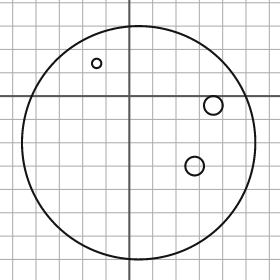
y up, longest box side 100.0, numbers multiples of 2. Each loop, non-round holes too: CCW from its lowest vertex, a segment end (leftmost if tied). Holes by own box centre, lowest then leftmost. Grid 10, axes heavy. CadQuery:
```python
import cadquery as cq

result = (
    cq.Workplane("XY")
    .moveTo(4.0, -20.0)
    .circle(50.0)
    .moveTo(28.0, -30.0)
    .circle(4.0)
    .moveTo(36.0, -4.0)
    .circle(4.0)
    .moveTo(-14.0, 14.0)
    .circle(2.0)
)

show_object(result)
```